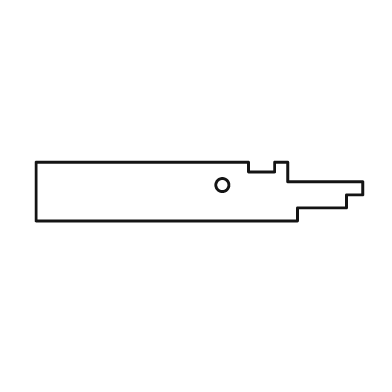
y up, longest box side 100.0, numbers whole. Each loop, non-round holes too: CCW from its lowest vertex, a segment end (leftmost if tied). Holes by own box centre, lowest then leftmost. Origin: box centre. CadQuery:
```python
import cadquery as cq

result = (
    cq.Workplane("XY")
    .moveTo(-50.0, -9.0)
    .lineTo(30.0, -9.0)
    .lineTo(30.0, -5.0)
    .lineTo(45.0, -5.0)
    .lineTo(45.0, -1.0)
    .lineTo(50.0, -1.0)
    .lineTo(50.0, 3.0)
    .lineTo(27.0, 3.0)
    .lineTo(27.0, 9.0)
    .lineTo(23.0, 9.0)
    .lineTo(23.0, 6.0)
    .lineTo(15.0, 6.0)
    .lineTo(15.0, 9.0)
    .lineTo(-50.0, 9.0)
    .close()
    .moveTo(7.0, 2.0)
    .circle(2.0)
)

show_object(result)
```